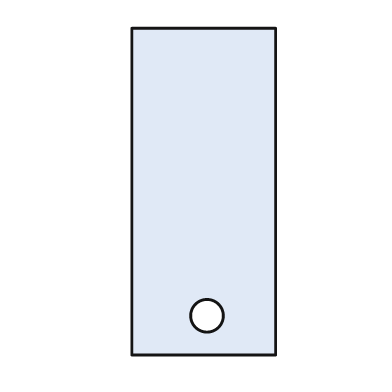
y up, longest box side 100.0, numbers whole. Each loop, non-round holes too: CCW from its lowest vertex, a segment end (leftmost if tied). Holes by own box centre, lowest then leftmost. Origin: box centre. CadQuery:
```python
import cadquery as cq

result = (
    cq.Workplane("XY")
    .moveTo(-22.0, -50.0)
    .lineTo(22.0, -50.0)
    .lineTo(22.0, 50.0)
    .lineTo(-22.0, 50.0)
    .close()
    .moveTo(1.0, -38.0)
    .circle(5.0)
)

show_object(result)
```